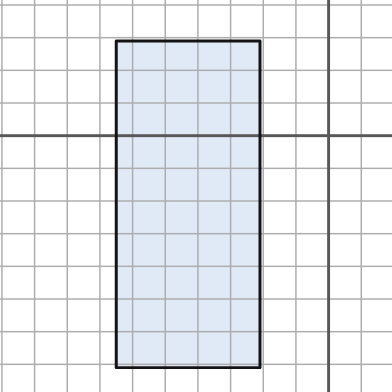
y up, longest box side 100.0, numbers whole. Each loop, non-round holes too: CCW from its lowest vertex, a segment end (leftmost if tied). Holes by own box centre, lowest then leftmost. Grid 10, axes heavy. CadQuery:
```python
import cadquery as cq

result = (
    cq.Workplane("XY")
    .moveTo(-65.0, -71.0)
    .lineTo(-21.0, -71.0)
    .lineTo(-21.0, 29.0)
    .lineTo(-65.0, 29.0)
    .close()
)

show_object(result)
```